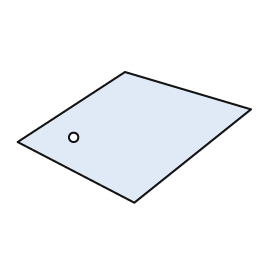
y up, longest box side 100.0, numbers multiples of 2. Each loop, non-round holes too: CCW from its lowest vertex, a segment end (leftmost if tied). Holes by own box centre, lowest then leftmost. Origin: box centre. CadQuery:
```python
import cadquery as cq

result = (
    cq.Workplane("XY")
    .moveTo(0.0, -28.0)
    .lineTo(50.0, 12.0)
    .lineTo(-4.0, 28.0)
    .lineTo(-50.0, -2.0)
    .close()
    .moveTo(-26.0, 0.0)
    .circle(2.0)
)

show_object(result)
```